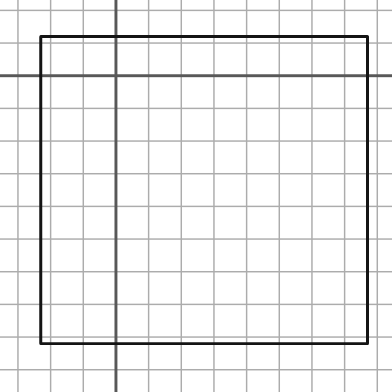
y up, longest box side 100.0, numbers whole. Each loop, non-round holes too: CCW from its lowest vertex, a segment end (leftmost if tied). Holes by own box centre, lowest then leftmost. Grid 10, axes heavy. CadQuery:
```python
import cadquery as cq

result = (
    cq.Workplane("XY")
    .moveTo(-23.0, -82.0)
    .lineTo(77.0, -82.0)
    .lineTo(77.0, 12.0)
    .lineTo(-23.0, 12.0)
    .close()
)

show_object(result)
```